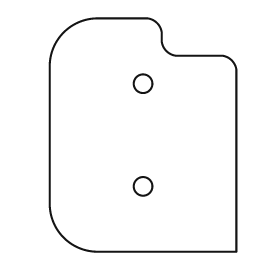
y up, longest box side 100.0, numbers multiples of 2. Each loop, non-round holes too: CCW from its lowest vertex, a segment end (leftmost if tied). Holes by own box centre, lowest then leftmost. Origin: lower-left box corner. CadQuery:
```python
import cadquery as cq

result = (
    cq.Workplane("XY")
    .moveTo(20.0, 0.0)
    .lineTo(80.0, 0.0)
    .lineTo(80.0, 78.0)
    .threePointArc((78.0, 82.0), (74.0, 84.0))
    .lineTo(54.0, 84.0)
    .threePointArc((50.0, 86.0), (48.0, 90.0))
    .lineTo(48.0, 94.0)
    .threePointArc((46.0, 98.0), (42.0, 100.0))
    .lineTo(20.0, 100.0)
    .threePointArc((6.0, 94.0), (0.0, 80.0))
    .lineTo(0.0, 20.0)
    .threePointArc((6.0, 6.0), (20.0, 0.0))
    .close()
    .moveTo(40.0, 28.0)
    .circle(4.0)
    .moveTo(40.0, 72.0)
    .circle(4.0)
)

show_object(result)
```